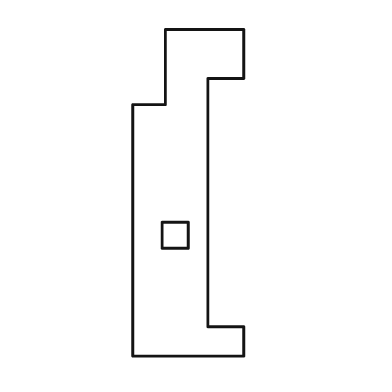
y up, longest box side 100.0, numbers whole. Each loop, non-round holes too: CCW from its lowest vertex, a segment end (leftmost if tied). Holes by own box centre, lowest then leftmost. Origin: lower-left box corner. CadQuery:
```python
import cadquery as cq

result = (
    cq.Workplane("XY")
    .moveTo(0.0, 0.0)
    .lineTo(34.0, 0.0)
    .lineTo(34.0, 9.0)
    .lineTo(23.0, 9.0)
    .lineTo(23.0, 85.0)
    .lineTo(34.0, 85.0)
    .lineTo(34.0, 100.0)
    .lineTo(10.0, 100.0)
    .lineTo(10.0, 77.0)
    .lineTo(0.0, 77.0)
    .close()
    .moveTo(9.0, 33.0)
    .lineTo(17.0, 33.0)
    .lineTo(17.0, 41.0)
    .lineTo(9.0, 41.0)
    .close()
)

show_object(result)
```